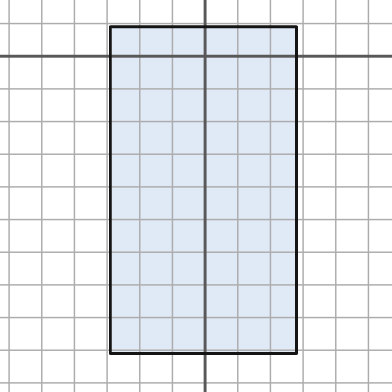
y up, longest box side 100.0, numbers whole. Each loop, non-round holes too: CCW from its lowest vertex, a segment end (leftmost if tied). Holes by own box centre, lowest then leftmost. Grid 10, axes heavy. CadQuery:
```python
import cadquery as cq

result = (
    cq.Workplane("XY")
    .moveTo(-29.0, -91.0)
    .lineTo(28.0, -91.0)
    .lineTo(28.0, 9.0)
    .lineTo(-29.0, 9.0)
    .close()
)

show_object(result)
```